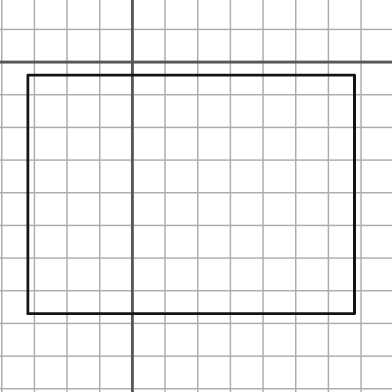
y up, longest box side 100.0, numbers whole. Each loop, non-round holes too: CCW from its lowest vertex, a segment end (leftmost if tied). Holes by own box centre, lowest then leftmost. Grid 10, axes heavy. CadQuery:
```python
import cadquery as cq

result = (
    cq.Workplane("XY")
    .moveTo(-32.0, -77.0)
    .lineTo(68.0, -77.0)
    .lineTo(68.0, -4.0)
    .lineTo(-32.0, -4.0)
    .close()
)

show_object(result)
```